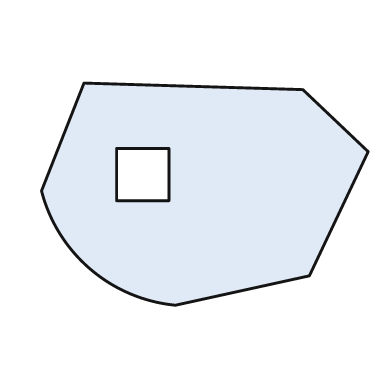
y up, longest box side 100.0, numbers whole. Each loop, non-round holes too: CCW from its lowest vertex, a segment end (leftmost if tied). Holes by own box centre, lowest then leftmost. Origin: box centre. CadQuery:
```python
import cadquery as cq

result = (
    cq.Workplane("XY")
    .moveTo(-9.0, -34.0)
    .lineTo(32.0, -25.0)
    .lineTo(50.0, 13.0)
    .lineTo(30.0, 32.0)
    .lineTo(-37.0, 34.0)
    .lineTo(-50.0, 1.0)
    .threePointArc((-35.0, -23.0), (-9.0, -34.0))
    .close()
    .moveTo(-27.0, -2.0)
    .lineTo(-11.0, -2.0)
    .lineTo(-11.0, 14.0)
    .lineTo(-27.0, 14.0)
    .close()
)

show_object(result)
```